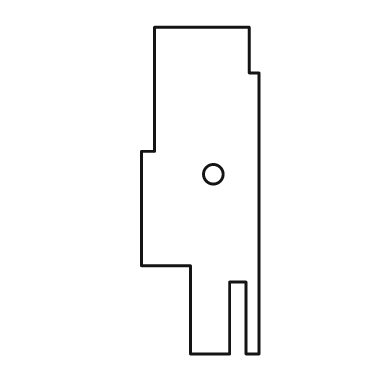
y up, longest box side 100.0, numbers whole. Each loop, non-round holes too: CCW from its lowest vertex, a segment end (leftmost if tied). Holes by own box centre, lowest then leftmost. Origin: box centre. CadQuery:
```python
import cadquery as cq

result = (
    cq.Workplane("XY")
    .moveTo(-3.0, -50.0)
    .lineTo(9.0, -50.0)
    .lineTo(9.0, -28.0)
    .lineTo(14.0, -28.0)
    .lineTo(14.0, -50.0)
    .lineTo(18.0, -50.0)
    .lineTo(18.0, 36.0)
    .lineTo(15.0, 36.0)
    .lineTo(15.0, 50.0)
    .lineTo(-14.0, 50.0)
    .lineTo(-14.0, 12.0)
    .lineTo(-18.0, 12.0)
    .lineTo(-18.0, -23.0)
    .lineTo(-3.0, -23.0)
    .close()
    .moveTo(4.0, 5.0)
    .circle(3.0)
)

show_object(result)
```